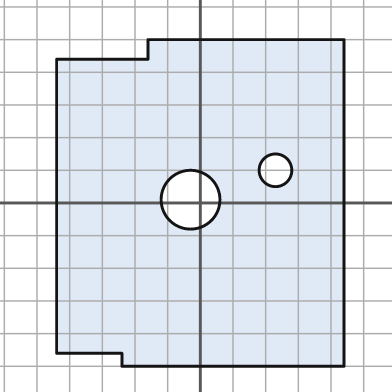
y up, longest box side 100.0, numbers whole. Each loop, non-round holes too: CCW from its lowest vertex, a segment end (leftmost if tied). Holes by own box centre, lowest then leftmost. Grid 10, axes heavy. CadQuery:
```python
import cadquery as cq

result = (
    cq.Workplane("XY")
    .moveTo(-24.0, -50.0)
    .lineTo(44.0, -50.0)
    .lineTo(44.0, 50.0)
    .lineTo(-16.0, 50.0)
    .lineTo(-16.0, 44.0)
    .lineTo(-44.0, 44.0)
    .lineTo(-44.0, -46.0)
    .lineTo(-24.0, -46.0)
    .close()
    .moveTo(-3.0, 1.0)
    .circle(9.0)
    .moveTo(23.0, 10.0)
    .circle(5.0)
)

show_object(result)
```